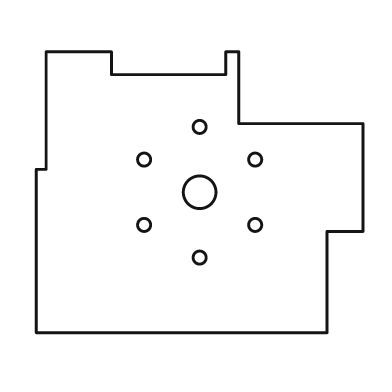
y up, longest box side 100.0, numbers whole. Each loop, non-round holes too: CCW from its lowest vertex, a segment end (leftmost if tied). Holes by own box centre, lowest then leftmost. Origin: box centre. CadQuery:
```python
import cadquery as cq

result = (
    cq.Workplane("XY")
    .moveTo(-50.0, -43.0)
    .lineTo(39.0, -43.0)
    .lineTo(39.0, -12.0)
    .lineTo(50.0, -12.0)
    .lineTo(50.0, 21.0)
    .lineTo(12.0, 21.0)
    .lineTo(12.0, 43.0)
    .lineTo(8.0, 43.0)
    .lineTo(8.0, 36.0)
    .lineTo(-27.0, 36.0)
    .lineTo(-27.0, 43.0)
    .lineTo(-47.0, 43.0)
    .lineTo(-47.0, 7.0)
    .lineTo(-50.0, 7.0)
    .close()
    .moveTo(0.0, -20.0)
    .circle(2.0)
    .moveTo(-17.0, -10.0)
    .circle(2.0)
    .moveTo(17.0, -10.0)
    .circle(2.0)
    .moveTo(0.0, 0.0)
    .circle(5.0)
    .moveTo(-17.0, 10.0)
    .circle(2.0)
    .moveTo(17.0, 10.0)
    .circle(2.0)
    .moveTo(0.0, 20.0)
    .circle(2.0)
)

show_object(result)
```